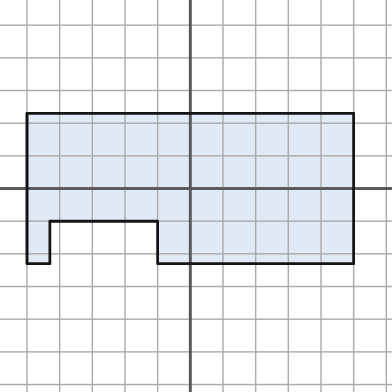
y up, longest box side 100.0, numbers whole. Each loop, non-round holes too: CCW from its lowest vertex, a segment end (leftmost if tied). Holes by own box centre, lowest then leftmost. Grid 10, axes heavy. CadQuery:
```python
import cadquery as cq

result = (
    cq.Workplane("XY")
    .moveTo(-50.0, -23.0)
    .lineTo(-43.0, -23.0)
    .lineTo(-43.0, -10.0)
    .lineTo(-10.0, -10.0)
    .lineTo(-10.0, -23.0)
    .lineTo(50.0, -23.0)
    .lineTo(50.0, 23.0)
    .lineTo(-50.0, 23.0)
    .close()
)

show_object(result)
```